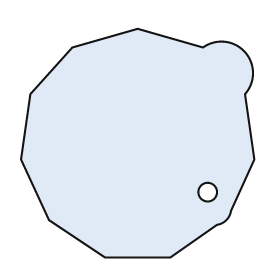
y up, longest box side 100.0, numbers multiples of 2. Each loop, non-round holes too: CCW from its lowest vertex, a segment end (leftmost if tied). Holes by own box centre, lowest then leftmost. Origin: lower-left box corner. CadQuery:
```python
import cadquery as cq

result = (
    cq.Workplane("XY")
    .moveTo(36.0, 0.0)
    .lineTo(64.0, 0.0)
    .lineTo(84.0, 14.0)
    .threePointArc((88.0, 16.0), (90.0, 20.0))
    .lineTo(100.0, 42.0)
    .lineTo(96.0, 70.0)
    .threePointArc((96.0, 88.0), (78.0, 90.0))
    .lineTo(50.0, 98.0)
    .lineTo(22.0, 90.0)
    .lineTo(4.0, 70.0)
    .lineTo(0.0, 42.0)
    .lineTo(12.0, 16.0)
    .close()
    .moveTo(80.0, 28.0)
    .circle(4.0)
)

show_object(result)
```